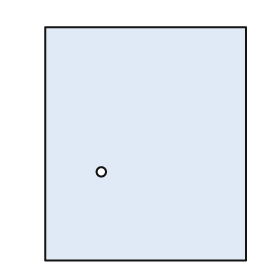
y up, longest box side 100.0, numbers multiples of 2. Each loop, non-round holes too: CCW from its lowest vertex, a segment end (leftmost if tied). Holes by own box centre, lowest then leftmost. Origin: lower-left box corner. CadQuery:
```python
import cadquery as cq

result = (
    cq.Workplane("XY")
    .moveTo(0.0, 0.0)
    .lineTo(86.0, 0.0)
    .lineTo(86.0, 100.0)
    .lineTo(0.0, 100.0)
    .close()
    .moveTo(24.0, 38.0)
    .circle(2.0)
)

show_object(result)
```